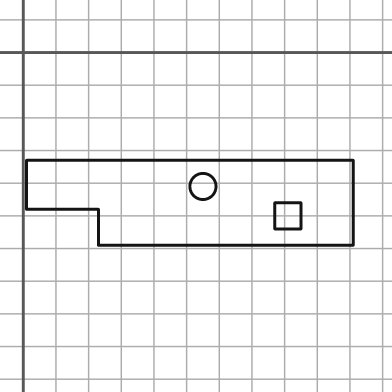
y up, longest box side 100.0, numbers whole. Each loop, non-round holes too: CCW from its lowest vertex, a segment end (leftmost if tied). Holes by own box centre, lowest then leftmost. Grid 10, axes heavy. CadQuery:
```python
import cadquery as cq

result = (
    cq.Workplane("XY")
    .moveTo(23.0, -59.0)
    .lineTo(101.0, -59.0)
    .lineTo(101.0, -33.0)
    .lineTo(1.0, -33.0)
    .lineTo(1.0, -48.0)
    .lineTo(23.0, -48.0)
    .close()
    .moveTo(77.0, -54.0)
    .lineTo(85.0, -54.0)
    .lineTo(85.0, -46.0)
    .lineTo(77.0, -46.0)
    .close()
    .moveTo(55.0, -41.0)
    .circle(4.0)
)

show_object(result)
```